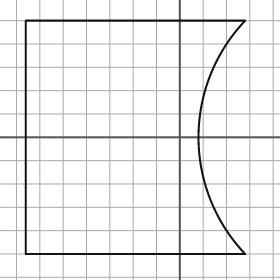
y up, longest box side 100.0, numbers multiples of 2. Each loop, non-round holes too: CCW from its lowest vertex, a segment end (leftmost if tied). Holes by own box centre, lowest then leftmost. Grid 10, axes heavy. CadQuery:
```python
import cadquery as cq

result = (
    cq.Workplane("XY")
    .moveTo(-66.0, -50.0)
    .lineTo(28.0, -50.0)
    .threePointArc((8.0, 0.0), (28.0, 50.0))
    .lineTo(-66.0, 50.0)
    .close()
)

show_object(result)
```